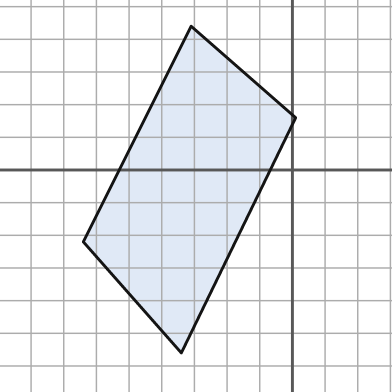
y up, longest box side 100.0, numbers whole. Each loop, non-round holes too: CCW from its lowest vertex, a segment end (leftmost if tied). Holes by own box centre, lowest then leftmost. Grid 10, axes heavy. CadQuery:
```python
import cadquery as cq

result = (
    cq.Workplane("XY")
    .moveTo(-34.0, -56.0)
    .lineTo(1.0, 16.0)
    .lineTo(-31.0, 44.0)
    .lineTo(-64.0, -22.0)
    .close()
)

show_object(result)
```